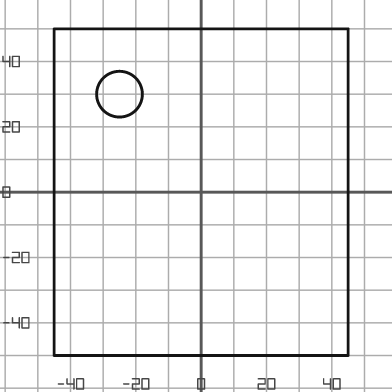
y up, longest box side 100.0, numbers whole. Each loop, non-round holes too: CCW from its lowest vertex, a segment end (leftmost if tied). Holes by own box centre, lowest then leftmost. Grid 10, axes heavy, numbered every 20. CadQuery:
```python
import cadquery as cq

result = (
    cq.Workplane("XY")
    .moveTo(-45.0, -50.0)
    .lineTo(45.0, -50.0)
    .lineTo(45.0, 50.0)
    .lineTo(-45.0, 50.0)
    .close()
    .moveTo(-25.0, 30.0)
    .circle(7.0)
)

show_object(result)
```